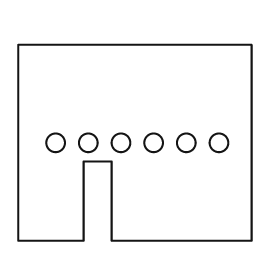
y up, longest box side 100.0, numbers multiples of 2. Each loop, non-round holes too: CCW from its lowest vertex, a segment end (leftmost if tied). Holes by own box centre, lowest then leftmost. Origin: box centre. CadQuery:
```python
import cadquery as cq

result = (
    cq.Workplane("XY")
    .moveTo(-50.0, -42.0)
    .lineTo(-22.0, -42.0)
    .lineTo(-22.0, -8.0)
    .lineTo(-10.0, -8.0)
    .lineTo(-10.0, -42.0)
    .lineTo(50.0, -42.0)
    .lineTo(50.0, 42.0)
    .lineTo(-50.0, 42.0)
    .close()
    .moveTo(-34.0, 0.0)
    .circle(4.0)
    .moveTo(-20.0, 0.0)
    .circle(4.0)
    .moveTo(-6.0, 0.0)
    .circle(4.0)
    .moveTo(8.0, 0.0)
    .circle(4.0)
    .moveTo(22.0, 0.0)
    .circle(4.0)
    .moveTo(36.0, 0.0)
    .circle(4.0)
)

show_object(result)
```